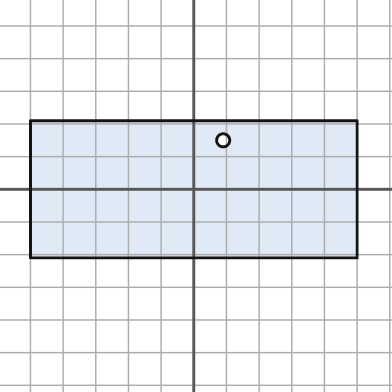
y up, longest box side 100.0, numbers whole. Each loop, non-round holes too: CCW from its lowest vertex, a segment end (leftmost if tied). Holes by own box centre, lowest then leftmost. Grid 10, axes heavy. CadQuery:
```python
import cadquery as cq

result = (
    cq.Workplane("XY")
    .moveTo(-50.0, -21.0)
    .lineTo(50.0, -21.0)
    .lineTo(50.0, 21.0)
    .lineTo(-50.0, 21.0)
    .close()
    .moveTo(9.0, 15.0)
    .circle(2.0)
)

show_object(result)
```